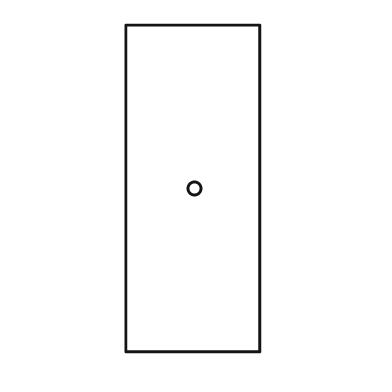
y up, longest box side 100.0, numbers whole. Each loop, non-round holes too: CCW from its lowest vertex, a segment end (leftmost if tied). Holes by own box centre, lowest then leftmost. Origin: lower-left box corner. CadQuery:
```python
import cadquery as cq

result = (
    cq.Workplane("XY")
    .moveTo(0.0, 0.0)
    .lineTo(41.0, 0.0)
    .lineTo(41.0, 100.0)
    .lineTo(0.0, 100.0)
    .close()
    .moveTo(21.0, 50.0)
    .circle(2.0)
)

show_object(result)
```